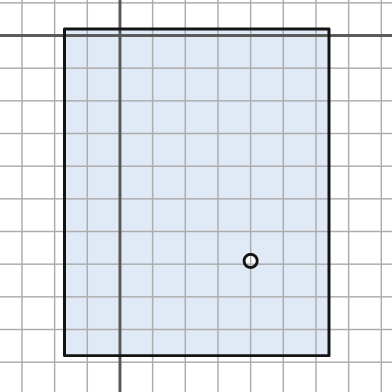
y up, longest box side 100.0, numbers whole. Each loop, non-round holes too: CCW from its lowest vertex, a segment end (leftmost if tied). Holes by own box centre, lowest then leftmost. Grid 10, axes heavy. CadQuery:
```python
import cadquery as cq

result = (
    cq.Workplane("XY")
    .moveTo(-17.0, -98.0)
    .lineTo(64.0, -98.0)
    .lineTo(64.0, 2.0)
    .lineTo(-17.0, 2.0)
    .close()
    .moveTo(40.0, -69.0)
    .circle(2.0)
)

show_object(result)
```